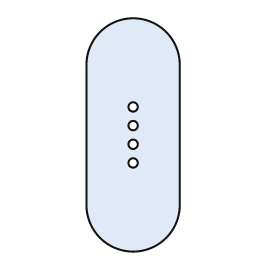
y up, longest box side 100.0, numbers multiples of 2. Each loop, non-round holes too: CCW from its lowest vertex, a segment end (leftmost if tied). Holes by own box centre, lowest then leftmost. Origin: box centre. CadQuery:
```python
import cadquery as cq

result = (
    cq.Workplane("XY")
    .moveTo(-20.0, -30.0)
    .threePointArc((0.0, -50.0), (20.0, -30.0))
    .lineTo(20.0, 30.0)
    .threePointArc((0.0, 50.0), (-20.0, 30.0))
    .close()
    .moveTo(0.0, -12.0)
    .circle(2.0)
    .moveTo(0.0, -4.0)
    .circle(2.0)
    .moveTo(0.0, 4.0)
    .circle(2.0)
    .moveTo(0.0, 12.0)
    .circle(2.0)
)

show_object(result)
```